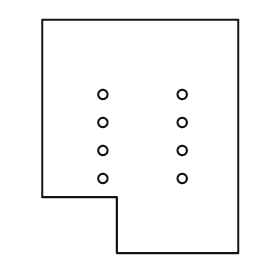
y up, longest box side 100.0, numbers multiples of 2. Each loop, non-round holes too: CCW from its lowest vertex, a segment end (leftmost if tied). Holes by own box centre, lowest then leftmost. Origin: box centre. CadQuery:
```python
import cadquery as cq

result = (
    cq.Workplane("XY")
    .moveTo(-10.0, -50.0)
    .lineTo(42.0, -50.0)
    .lineTo(42.0, 50.0)
    .lineTo(-42.0, 50.0)
    .lineTo(-42.0, -26.0)
    .lineTo(-10.0, -26.0)
    .close()
    .moveTo(-16.0, -18.0)
    .circle(2.0)
    .moveTo(18.0, -18.0)
    .circle(2.0)
    .moveTo(-16.0, -6.0)
    .circle(2.0)
    .moveTo(18.0, -6.0)
    .circle(2.0)
    .moveTo(-16.0, 6.0)
    .circle(2.0)
    .moveTo(18.0, 6.0)
    .circle(2.0)
    .moveTo(-16.0, 18.0)
    .circle(2.0)
    .moveTo(18.0, 18.0)
    .circle(2.0)
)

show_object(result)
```